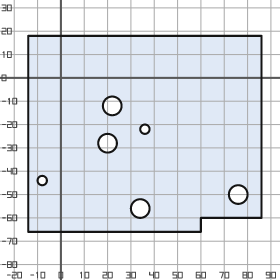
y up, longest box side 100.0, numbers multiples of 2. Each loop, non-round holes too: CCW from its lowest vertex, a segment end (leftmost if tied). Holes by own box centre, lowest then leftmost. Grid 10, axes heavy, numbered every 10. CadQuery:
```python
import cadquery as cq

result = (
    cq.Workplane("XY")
    .moveTo(-14.0, -66.0)
    .lineTo(60.0, -66.0)
    .lineTo(60.0, -60.0)
    .lineTo(86.0, -60.0)
    .lineTo(86.0, 18.0)
    .lineTo(-14.0, 18.0)
    .close()
    .moveTo(34.0, -56.0)
    .circle(4.0)
    .moveTo(76.0, -50.0)
    .circle(4.0)
    .moveTo(-8.0, -44.0)
    .circle(2.0)
    .moveTo(20.0, -28.0)
    .circle(4.0)
    .moveTo(36.0, -22.0)
    .circle(2.0)
    .moveTo(22.0, -12.0)
    .circle(4.0)
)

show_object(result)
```